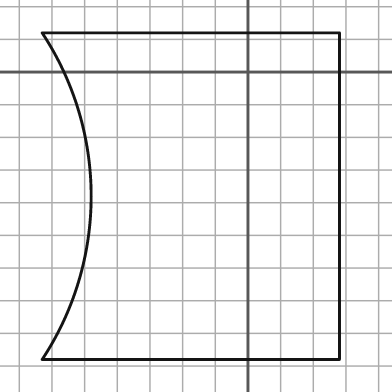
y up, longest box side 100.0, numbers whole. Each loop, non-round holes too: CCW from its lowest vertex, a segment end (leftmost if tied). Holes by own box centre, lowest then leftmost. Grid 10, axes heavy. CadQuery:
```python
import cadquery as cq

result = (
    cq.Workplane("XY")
    .moveTo(-63.0, -88.0)
    .lineTo(28.0, -88.0)
    .lineTo(28.0, 12.0)
    .lineTo(-63.0, 12.0)
    .threePointArc((-48.0, -38.0), (-63.0, -88.0))
    .close()
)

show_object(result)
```